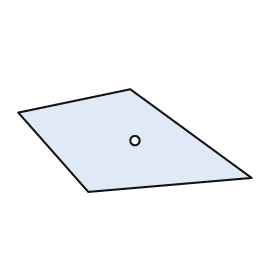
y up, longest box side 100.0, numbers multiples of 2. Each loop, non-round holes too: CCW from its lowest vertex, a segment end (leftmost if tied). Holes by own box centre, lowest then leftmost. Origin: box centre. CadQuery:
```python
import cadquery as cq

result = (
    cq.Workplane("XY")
    .moveTo(-20.0, -22.0)
    .lineTo(50.0, -16.0)
    .lineTo(-2.0, 22.0)
    .lineTo(-50.0, 12.0)
    .close()
    .moveTo(0.0, 0.0)
    .circle(2.0)
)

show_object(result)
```